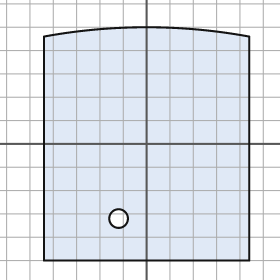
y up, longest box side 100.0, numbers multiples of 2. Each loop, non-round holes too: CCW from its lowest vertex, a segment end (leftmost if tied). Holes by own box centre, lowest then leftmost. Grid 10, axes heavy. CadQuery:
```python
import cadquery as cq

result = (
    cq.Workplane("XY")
    .moveTo(-44.0, -50.0)
    .lineTo(44.0, -50.0)
    .lineTo(44.0, 46.0)
    .threePointArc((0.0, 50.0), (-44.0, 46.0))
    .close()
    .moveTo(-12.0, -32.0)
    .circle(4.0)
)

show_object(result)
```